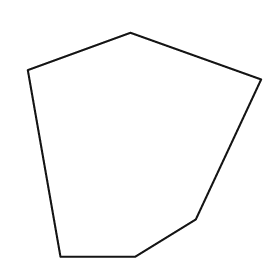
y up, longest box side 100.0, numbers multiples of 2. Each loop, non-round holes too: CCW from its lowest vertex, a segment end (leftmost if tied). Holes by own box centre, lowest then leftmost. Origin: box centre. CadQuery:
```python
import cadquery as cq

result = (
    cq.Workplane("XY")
    .moveTo(-36.0, -48.0)
    .lineTo(-4.0, -48.0)
    .lineTo(22.0, -32.0)
    .lineTo(50.0, 28.0)
    .lineTo(-6.0, 48.0)
    .lineTo(-50.0, 32.0)
    .close()
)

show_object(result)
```